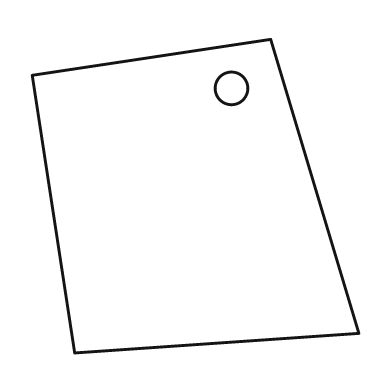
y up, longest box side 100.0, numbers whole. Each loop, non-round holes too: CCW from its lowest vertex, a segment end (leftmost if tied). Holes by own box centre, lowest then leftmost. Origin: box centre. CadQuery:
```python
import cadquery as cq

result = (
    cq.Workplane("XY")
    .moveTo(-37.0, -48.0)
    .lineTo(50.0, -42.0)
    .lineTo(23.0, 48.0)
    .lineTo(-50.0, 37.0)
    .close()
    .moveTo(11.0, 33.0)
    .circle(5.0)
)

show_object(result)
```